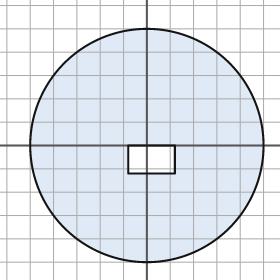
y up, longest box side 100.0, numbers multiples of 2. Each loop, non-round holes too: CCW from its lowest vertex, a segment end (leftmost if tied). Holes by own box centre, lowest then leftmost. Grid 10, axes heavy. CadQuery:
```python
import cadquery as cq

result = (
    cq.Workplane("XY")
    .moveTo(0.0, 0.0)
    .circle(50.0)
    .moveTo(-8.0, -12.0)
    .lineTo(12.0, -12.0)
    .lineTo(12.0, 0.0)
    .lineTo(-8.0, 0.0)
    .close()
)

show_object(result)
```